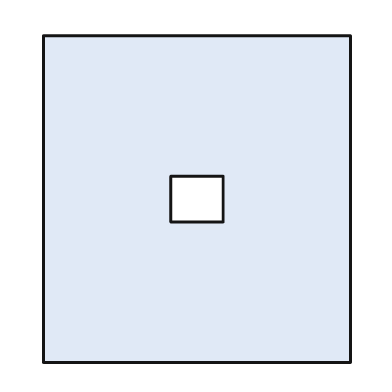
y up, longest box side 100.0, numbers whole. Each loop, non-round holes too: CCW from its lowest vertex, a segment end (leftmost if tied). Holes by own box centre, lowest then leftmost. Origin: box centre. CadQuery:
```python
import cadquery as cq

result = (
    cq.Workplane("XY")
    .moveTo(-47.0, -50.0)
    .lineTo(47.0, -50.0)
    .lineTo(47.0, 50.0)
    .lineTo(-47.0, 50.0)
    .close()
    .moveTo(-8.0, -7.0)
    .lineTo(8.0, -7.0)
    .lineTo(8.0, 7.0)
    .lineTo(-8.0, 7.0)
    .close()
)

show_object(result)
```